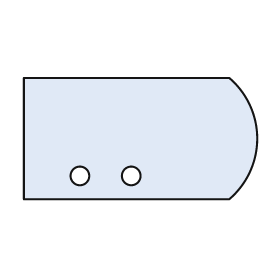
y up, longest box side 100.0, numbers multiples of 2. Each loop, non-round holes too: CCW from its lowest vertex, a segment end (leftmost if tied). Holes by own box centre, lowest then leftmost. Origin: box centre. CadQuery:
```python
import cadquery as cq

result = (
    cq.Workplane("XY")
    .moveTo(-50.0, -26.0)
    .lineTo(38.0, -26.0)
    .threePointArc((50.0, 0.0), (38.0, 26.0))
    .lineTo(-50.0, 26.0)
    .close()
    .moveTo(-26.0, -16.0)
    .circle(4.0)
    .moveTo(-4.0, -16.0)
    .circle(4.0)
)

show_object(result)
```